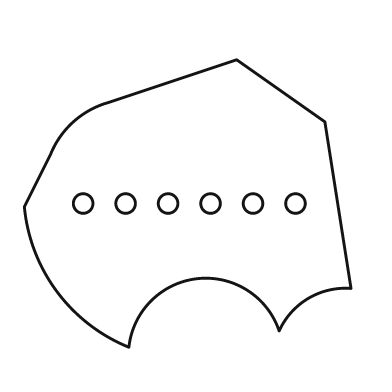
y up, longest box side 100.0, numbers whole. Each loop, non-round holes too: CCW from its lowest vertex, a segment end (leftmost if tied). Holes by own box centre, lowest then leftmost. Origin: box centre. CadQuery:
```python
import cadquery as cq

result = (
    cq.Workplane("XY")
    .moveTo(-18.0, -44.0)
    .threePointArc((3.0, -23.0), (28.0, -39.0))
    .threePointArc((37.0, -29.0), (50.0, -26.0))
    .lineTo(42.0, 25.0)
    .lineTo(15.0, 44.0)
    .lineTo(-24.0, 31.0)
    .threePointArc((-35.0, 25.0), (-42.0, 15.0))
    .lineTo(-50.0, -1.0)
    .threePointArc((-40.0, -27.0), (-18.0, -44.0))
    .close()
    .moveTo(-32.0, 0.0)
    .circle(3.0)
    .moveTo(-19.0, 0.0)
    .circle(3.0)
    .moveTo(-6.0, 0.0)
    .circle(3.0)
    .moveTo(7.0, 0.0)
    .circle(3.0)
    .moveTo(20.0, 0.0)
    .circle(3.0)
    .moveTo(33.0, 0.0)
    .circle(3.0)
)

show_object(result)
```